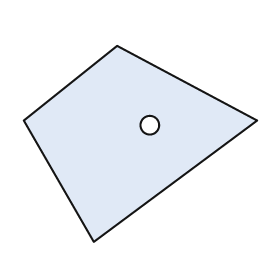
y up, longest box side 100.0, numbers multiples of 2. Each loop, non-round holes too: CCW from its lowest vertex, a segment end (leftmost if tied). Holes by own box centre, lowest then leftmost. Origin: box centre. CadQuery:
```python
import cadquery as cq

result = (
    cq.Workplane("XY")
    .moveTo(-20.0, -42.0)
    .lineTo(50.0, 10.0)
    .lineTo(-10.0, 42.0)
    .lineTo(-50.0, 10.0)
    .close()
    .moveTo(4.0, 8.0)
    .circle(4.0)
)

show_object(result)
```